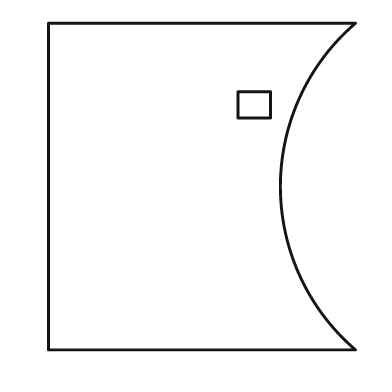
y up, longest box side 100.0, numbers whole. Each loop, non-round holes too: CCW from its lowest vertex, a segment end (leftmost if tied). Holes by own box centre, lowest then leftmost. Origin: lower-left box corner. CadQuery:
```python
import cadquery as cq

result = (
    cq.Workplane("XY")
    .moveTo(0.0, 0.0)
    .lineTo(94.0, 0.0)
    .threePointArc((71.0, 50.0), (94.0, 100.0))
    .lineTo(0.0, 100.0)
    .close()
    .moveTo(58.0, 71.0)
    .lineTo(68.0, 71.0)
    .lineTo(68.0, 79.0)
    .lineTo(58.0, 79.0)
    .close()
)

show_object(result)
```